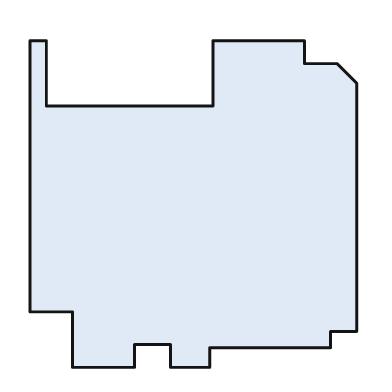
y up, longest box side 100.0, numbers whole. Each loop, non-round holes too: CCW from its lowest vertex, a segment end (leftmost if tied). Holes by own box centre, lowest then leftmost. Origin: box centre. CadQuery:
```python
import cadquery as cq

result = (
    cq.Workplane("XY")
    .moveTo(-37.0, -50.0)
    .lineTo(-18.0, -50.0)
    .lineTo(-18.0, -43.0)
    .lineTo(-7.0, -43.0)
    .lineTo(-7.0, -50.0)
    .lineTo(5.0, -50.0)
    .lineTo(5.0, -44.0)
    .lineTo(42.0, -44.0)
    .lineTo(42.0, -39.0)
    .lineTo(50.0, -39.0)
    .lineTo(50.0, 37.0)
    .lineTo(44.0, 43.0)
    .lineTo(34.0, 43.0)
    .lineTo(34.0, 50.0)
    .lineTo(6.0, 50.0)
    .lineTo(6.0, 30.0)
    .lineTo(-45.0, 30.0)
    .lineTo(-45.0, 50.0)
    .lineTo(-50.0, 50.0)
    .lineTo(-50.0, -33.0)
    .lineTo(-37.0, -33.0)
    .close()
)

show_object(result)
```